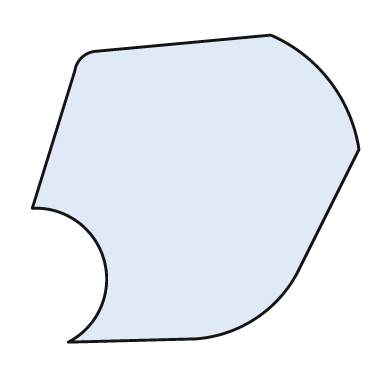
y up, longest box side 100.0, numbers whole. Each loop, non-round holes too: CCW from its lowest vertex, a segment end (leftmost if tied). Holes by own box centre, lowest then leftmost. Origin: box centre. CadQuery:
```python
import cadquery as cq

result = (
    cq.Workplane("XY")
    .moveTo(-39.0, -47.0)
    .lineTo(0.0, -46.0)
    .threePointArc((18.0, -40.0), (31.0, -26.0))
    .lineTo(50.0, 12.0)
    .threePointArc((41.0, 33.0), (23.0, 47.0))
    .lineTo(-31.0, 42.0)
    .threePointArc((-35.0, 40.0), (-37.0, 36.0))
    .lineTo(-50.0, -6.0)
    .threePointArc((-28.0, -22.0), (-39.0, -47.0))
    .close()
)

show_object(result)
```